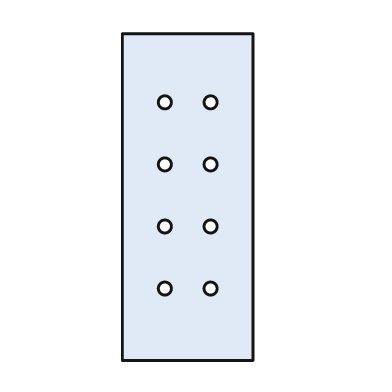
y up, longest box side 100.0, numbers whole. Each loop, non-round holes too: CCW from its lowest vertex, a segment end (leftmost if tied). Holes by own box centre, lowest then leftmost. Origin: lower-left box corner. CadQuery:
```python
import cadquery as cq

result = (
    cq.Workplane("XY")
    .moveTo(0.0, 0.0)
    .lineTo(40.0, 0.0)
    .lineTo(40.0, 100.0)
    .lineTo(0.0, 100.0)
    .close()
    .moveTo(13.0, 22.0)
    .circle(2.0)
    .moveTo(27.0, 22.0)
    .circle(2.0)
    .moveTo(13.0, 41.0)
    .circle(2.0)
    .moveTo(27.0, 41.0)
    .circle(2.0)
    .moveTo(13.0, 60.0)
    .circle(2.0)
    .moveTo(27.0, 60.0)
    .circle(2.0)
    .moveTo(13.0, 79.0)
    .circle(2.0)
    .moveTo(27.0, 79.0)
    .circle(2.0)
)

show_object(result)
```